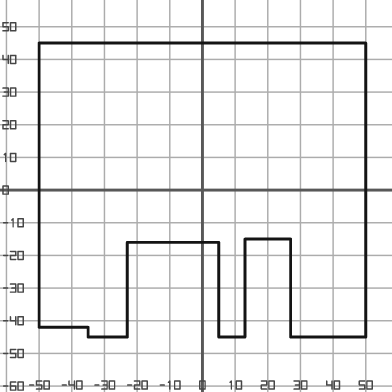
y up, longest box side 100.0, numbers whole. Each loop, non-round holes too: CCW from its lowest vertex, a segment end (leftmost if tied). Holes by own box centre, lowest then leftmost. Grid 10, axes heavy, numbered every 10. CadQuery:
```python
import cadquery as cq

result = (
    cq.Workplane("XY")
    .moveTo(-35.0, -45.0)
    .lineTo(-23.0, -45.0)
    .lineTo(-23.0, -16.0)
    .lineTo(5.0, -16.0)
    .lineTo(5.0, -45.0)
    .lineTo(13.0, -45.0)
    .lineTo(13.0, -15.0)
    .lineTo(27.0, -15.0)
    .lineTo(27.0, -45.0)
    .lineTo(50.0, -45.0)
    .lineTo(50.0, 45.0)
    .lineTo(-50.0, 45.0)
    .lineTo(-50.0, -42.0)
    .lineTo(-35.0, -42.0)
    .close()
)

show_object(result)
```